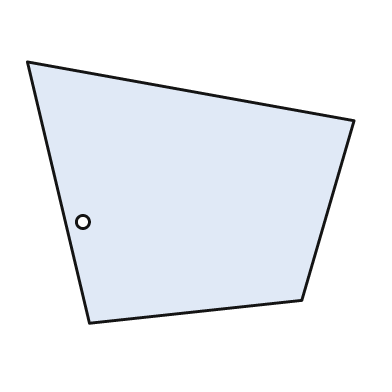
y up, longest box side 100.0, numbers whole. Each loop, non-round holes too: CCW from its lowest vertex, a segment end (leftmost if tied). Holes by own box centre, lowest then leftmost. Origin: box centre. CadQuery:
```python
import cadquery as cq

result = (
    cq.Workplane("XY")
    .moveTo(-31.0, -40.0)
    .lineTo(34.0, -33.0)
    .lineTo(50.0, 22.0)
    .lineTo(-50.0, 40.0)
    .close()
    .moveTo(-33.0, -9.0)
    .circle(2.0)
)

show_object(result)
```